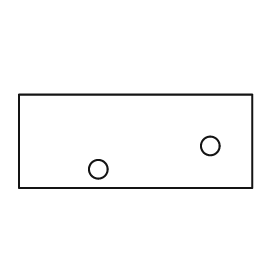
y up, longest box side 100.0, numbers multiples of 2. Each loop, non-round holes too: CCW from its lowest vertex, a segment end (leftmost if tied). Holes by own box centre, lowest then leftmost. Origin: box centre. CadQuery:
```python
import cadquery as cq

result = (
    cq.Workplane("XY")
    .moveTo(-50.0, -20.0)
    .lineTo(50.0, -20.0)
    .lineTo(50.0, 20.0)
    .lineTo(-50.0, 20.0)
    .close()
    .moveTo(-16.0, -12.0)
    .circle(4.0)
    .moveTo(32.0, -2.0)
    .circle(4.0)
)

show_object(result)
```